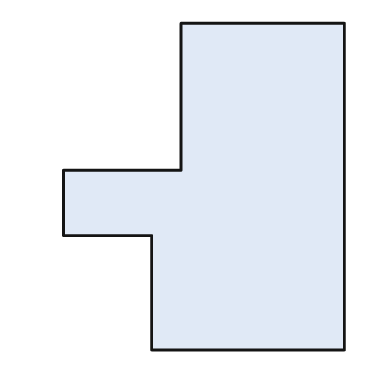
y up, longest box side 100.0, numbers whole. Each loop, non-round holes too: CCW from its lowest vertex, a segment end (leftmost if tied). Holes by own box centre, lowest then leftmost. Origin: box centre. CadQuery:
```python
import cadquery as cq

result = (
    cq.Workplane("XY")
    .moveTo(-16.0, -50.0)
    .lineTo(43.0, -50.0)
    .lineTo(43.0, 50.0)
    .lineTo(-7.0, 50.0)
    .lineTo(-7.0, 5.0)
    .lineTo(-43.0, 5.0)
    .lineTo(-43.0, -15.0)
    .lineTo(-16.0, -15.0)
    .close()
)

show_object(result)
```